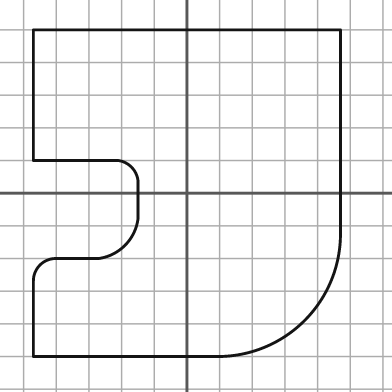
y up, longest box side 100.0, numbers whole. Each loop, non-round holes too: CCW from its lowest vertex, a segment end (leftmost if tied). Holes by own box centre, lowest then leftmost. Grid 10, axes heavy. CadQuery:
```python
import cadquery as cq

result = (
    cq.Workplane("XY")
    .moveTo(-47.0, -50.0)
    .lineTo(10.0, -50.0)
    .threePointArc((36.0, -39.0), (47.0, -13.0))
    .lineTo(47.0, 50.0)
    .lineTo(-47.0, 50.0)
    .lineTo(-47.0, 10.0)
    .lineTo(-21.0, 10.0)
    .threePointArc((-17.0, 8.0), (-15.0, 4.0))
    .lineTo(-15.0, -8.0)
    .threePointArc((-19.0, -16.0), (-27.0, -20.0))
    .lineTo(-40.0, -20.0)
    .threePointArc((-45.0, -22.0), (-47.0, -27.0))
    .close()
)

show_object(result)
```